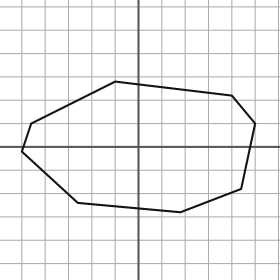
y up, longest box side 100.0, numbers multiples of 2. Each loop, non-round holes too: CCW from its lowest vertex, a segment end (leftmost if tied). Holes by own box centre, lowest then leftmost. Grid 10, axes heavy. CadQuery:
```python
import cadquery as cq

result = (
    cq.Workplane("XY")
    .moveTo(18.0, -28.0)
    .lineTo(44.0, -18.0)
    .lineTo(50.0, 10.0)
    .lineTo(40.0, 22.0)
    .lineTo(-10.0, 28.0)
    .lineTo(-46.0, 10.0)
    .lineTo(-50.0, -2.0)
    .lineTo(-26.0, -24.0)
    .close()
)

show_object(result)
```